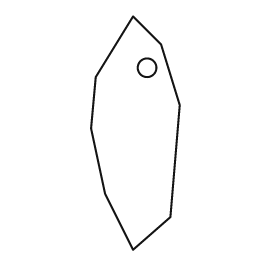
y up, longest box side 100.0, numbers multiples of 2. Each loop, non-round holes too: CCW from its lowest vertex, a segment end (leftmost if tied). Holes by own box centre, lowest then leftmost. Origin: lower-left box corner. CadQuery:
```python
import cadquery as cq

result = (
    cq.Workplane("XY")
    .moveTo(18.0, 0.0)
    .lineTo(34.0, 14.0)
    .lineTo(38.0, 62.0)
    .lineTo(30.0, 88.0)
    .lineTo(18.0, 100.0)
    .lineTo(2.0, 74.0)
    .lineTo(0.0, 52.0)
    .lineTo(6.0, 24.0)
    .close()
    .moveTo(24.0, 78.0)
    .circle(4.0)
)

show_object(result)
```